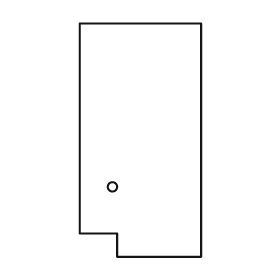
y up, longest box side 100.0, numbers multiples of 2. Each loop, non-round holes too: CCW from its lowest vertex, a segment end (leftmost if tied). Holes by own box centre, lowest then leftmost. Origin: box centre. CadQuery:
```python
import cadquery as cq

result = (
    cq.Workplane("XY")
    .moveTo(-10.0, -50.0)
    .lineTo(26.0, -50.0)
    .lineTo(26.0, 50.0)
    .lineTo(-26.0, 50.0)
    .lineTo(-26.0, -40.0)
    .lineTo(-10.0, -40.0)
    .close()
    .moveTo(-12.0, -20.0)
    .circle(2.0)
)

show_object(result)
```